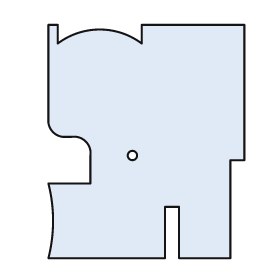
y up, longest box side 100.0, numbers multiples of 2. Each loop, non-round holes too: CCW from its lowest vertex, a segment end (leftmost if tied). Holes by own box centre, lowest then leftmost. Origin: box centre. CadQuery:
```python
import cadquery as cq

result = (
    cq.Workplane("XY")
    .moveTo(-42.0, -50.0)
    .lineTo(8.0, -50.0)
    .lineTo(8.0, -28.0)
    .lineTo(14.0, -28.0)
    .lineTo(14.0, -50.0)
    .lineTo(36.0, -50.0)
    .lineTo(36.0, -8.0)
    .lineTo(42.0, -8.0)
    .lineTo(42.0, 50.0)
    .lineTo(-2.0, 50.0)
    .lineTo(-2.0, 42.0)
    .threePointArc((-20.0, 48.0), (-38.0, 42.0))
    .lineTo(-38.0, 50.0)
    .lineTo(-42.0, 50.0)
    .lineTo(-42.0, 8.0)
    .threePointArc((-40.0, 4.0), (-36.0, 2.0))
    .lineTo(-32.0, 2.0)
    .threePointArc((-26.0, 0.0), (-24.0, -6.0))
    .lineTo(-24.0, -18.0)
    .lineTo(-42.0, -18.0)
    .threePointArc((-40.0, -34.0), (-42.0, -50.0))
    .close()
    .moveTo(-6.0, -6.0)
    .circle(2.0)
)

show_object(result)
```